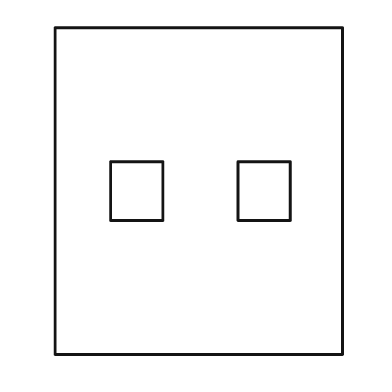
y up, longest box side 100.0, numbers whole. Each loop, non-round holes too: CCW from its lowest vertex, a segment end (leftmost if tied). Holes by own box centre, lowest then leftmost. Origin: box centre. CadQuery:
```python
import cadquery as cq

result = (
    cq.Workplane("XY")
    .moveTo(-44.0, -50.0)
    .lineTo(44.0, -50.0)
    .lineTo(44.0, 50.0)
    .lineTo(-44.0, 50.0)
    .close()
    .moveTo(-27.0, -9.0)
    .lineTo(-11.0, -9.0)
    .lineTo(-11.0, 9.0)
    .lineTo(-27.0, 9.0)
    .close()
    .moveTo(12.0, -9.0)
    .lineTo(28.0, -9.0)
    .lineTo(28.0, 9.0)
    .lineTo(12.0, 9.0)
    .close()
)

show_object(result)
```